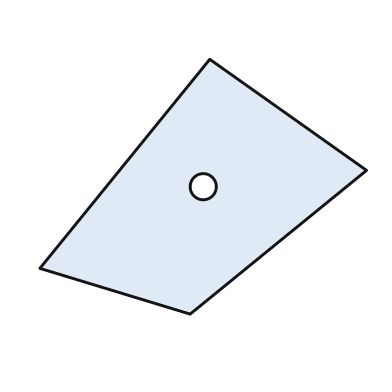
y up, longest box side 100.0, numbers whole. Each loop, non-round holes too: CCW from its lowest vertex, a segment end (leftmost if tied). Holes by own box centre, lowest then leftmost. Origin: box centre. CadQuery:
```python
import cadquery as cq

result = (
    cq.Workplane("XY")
    .moveTo(-4.0, -39.0)
    .lineTo(50.0, 5.0)
    .lineTo(2.0, 39.0)
    .lineTo(-50.0, -25.0)
    .close()
    .moveTo(0.0, 0.0)
    .circle(4.0)
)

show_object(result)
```